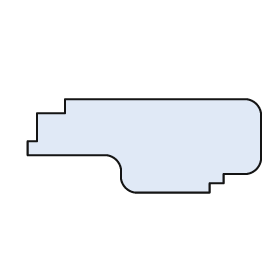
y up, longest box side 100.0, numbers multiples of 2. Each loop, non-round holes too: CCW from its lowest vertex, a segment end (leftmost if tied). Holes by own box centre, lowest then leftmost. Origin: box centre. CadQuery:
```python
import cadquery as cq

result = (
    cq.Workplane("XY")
    .moveTo(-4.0, -20.0)
    .lineTo(28.0, -20.0)
    .lineTo(28.0, -16.0)
    .lineTo(34.0, -16.0)
    .lineTo(34.0, -12.0)
    .lineTo(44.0, -12.0)
    .threePointArc((48.0, -10.0), (50.0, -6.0))
    .lineTo(50.0, 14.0)
    .threePointArc((48.0, 18.0), (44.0, 20.0))
    .lineTo(-34.0, 20.0)
    .lineTo(-34.0, 14.0)
    .lineTo(-46.0, 14.0)
    .lineTo(-46.0, 2.0)
    .lineTo(-50.0, 2.0)
    .lineTo(-50.0, -4.0)
    .lineTo(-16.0, -4.0)
    .threePointArc((-12.0, -6.0), (-10.0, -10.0))
    .lineTo(-10.0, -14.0)
    .threePointArc((-8.0, -18.0), (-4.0, -20.0))
    .close()
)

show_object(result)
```